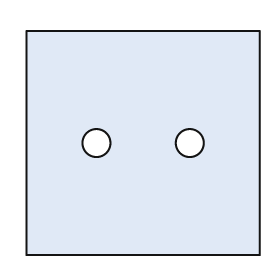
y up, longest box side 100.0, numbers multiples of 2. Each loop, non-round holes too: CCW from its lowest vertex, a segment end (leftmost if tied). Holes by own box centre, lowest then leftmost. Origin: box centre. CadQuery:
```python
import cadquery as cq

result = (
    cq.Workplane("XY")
    .moveTo(-50.0, -48.0)
    .lineTo(50.0, -48.0)
    .lineTo(50.0, 48.0)
    .lineTo(-50.0, 48.0)
    .close()
    .moveTo(-20.0, 0.0)
    .circle(6.0)
    .moveTo(20.0, 0.0)
    .circle(6.0)
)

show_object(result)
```